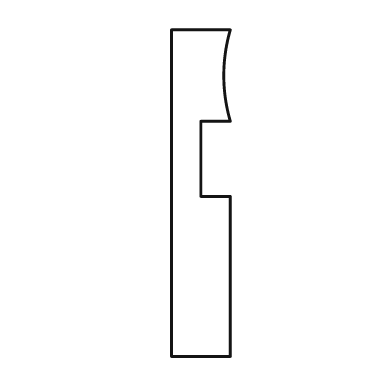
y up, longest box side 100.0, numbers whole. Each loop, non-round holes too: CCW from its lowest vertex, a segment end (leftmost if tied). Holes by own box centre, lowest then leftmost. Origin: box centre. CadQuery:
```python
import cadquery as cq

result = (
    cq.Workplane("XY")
    .moveTo(-9.0, -50.0)
    .lineTo(9.0, -50.0)
    .lineTo(9.0, -1.0)
    .lineTo(0.0, -1.0)
    .lineTo(0.0, 22.0)
    .lineTo(9.0, 22.0)
    .threePointArc((7.0, 36.0), (9.0, 50.0))
    .lineTo(-9.0, 50.0)
    .close()
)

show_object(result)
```